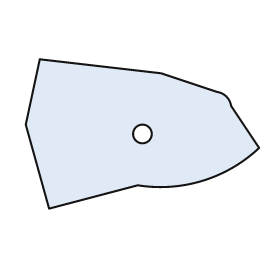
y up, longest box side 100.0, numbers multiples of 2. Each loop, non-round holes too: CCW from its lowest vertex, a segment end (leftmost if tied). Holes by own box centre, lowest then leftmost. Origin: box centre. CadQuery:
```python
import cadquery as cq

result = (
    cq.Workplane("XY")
    .moveTo(-40.0, -32.0)
    .lineTo(-2.0, -22.0)
    .threePointArc((26.0, -20.0), (50.0, -6.0))
    .lineTo(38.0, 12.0)
    .threePointArc((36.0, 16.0), (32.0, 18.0))
    .lineTo(8.0, 26.0)
    .lineTo(-44.0, 32.0)
    .lineTo(-50.0, 4.0)
    .close()
    .moveTo(0.0, 0.0)
    .circle(4.0)
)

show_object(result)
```